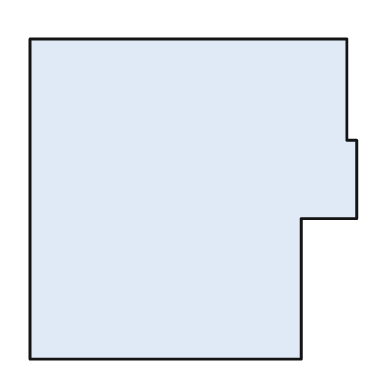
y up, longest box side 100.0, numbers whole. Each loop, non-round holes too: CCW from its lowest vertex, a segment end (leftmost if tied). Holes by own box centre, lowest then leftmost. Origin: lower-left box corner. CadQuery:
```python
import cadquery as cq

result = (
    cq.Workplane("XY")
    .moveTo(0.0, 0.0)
    .lineTo(83.0, 0.0)
    .lineTo(83.0, 43.0)
    .lineTo(100.0, 43.0)
    .lineTo(100.0, 67.0)
    .lineTo(97.0, 67.0)
    .lineTo(97.0, 98.0)
    .lineTo(0.0, 98.0)
    .close()
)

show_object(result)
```